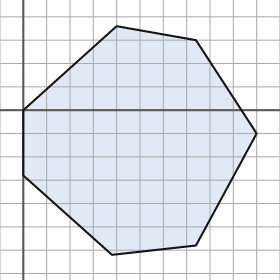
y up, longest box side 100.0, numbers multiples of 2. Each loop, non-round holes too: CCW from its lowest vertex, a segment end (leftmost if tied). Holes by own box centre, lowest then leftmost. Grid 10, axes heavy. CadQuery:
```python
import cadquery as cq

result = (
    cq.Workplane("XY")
    .moveTo(38.0, -62.0)
    .lineTo(74.0, -58.0)
    .lineTo(100.0, -10.0)
    .lineTo(74.0, 30.0)
    .lineTo(40.0, 36.0)
    .lineTo(0.0, 0.0)
    .lineTo(0.0, -28.0)
    .close()
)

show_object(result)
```